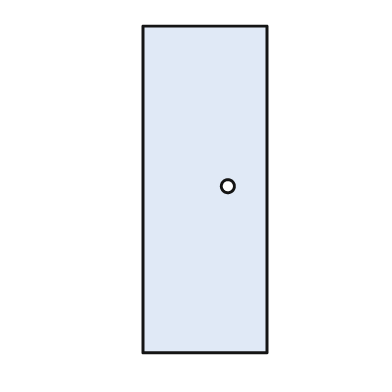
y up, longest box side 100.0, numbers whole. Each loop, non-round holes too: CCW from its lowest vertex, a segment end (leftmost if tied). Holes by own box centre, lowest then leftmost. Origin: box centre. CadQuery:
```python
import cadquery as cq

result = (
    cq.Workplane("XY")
    .moveTo(-19.0, -50.0)
    .lineTo(19.0, -50.0)
    .lineTo(19.0, 50.0)
    .lineTo(-19.0, 50.0)
    .close()
    .moveTo(7.0, 1.0)
    .circle(2.0)
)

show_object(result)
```